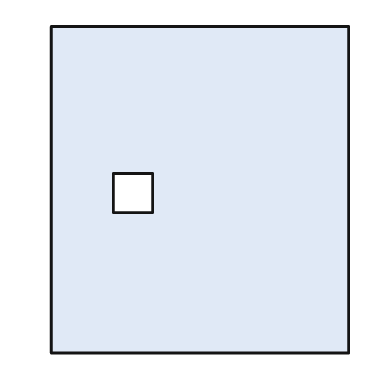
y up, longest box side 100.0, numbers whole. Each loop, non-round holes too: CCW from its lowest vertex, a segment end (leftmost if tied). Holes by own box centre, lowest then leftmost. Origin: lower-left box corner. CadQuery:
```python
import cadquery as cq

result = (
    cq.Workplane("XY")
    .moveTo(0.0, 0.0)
    .lineTo(91.0, 0.0)
    .lineTo(91.0, 100.0)
    .lineTo(0.0, 100.0)
    .close()
    .moveTo(19.0, 43.0)
    .lineTo(31.0, 43.0)
    .lineTo(31.0, 55.0)
    .lineTo(19.0, 55.0)
    .close()
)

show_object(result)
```